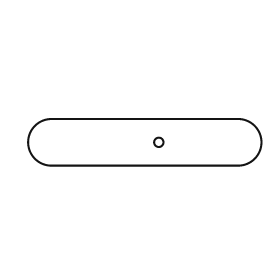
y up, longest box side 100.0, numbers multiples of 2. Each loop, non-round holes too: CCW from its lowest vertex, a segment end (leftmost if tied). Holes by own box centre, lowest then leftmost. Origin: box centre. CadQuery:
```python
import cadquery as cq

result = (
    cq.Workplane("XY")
    .moveTo(-40.0, -10.0)
    .lineTo(40.0, -10.0)
    .threePointArc((50.0, 0.0), (40.0, 10.0))
    .lineTo(-40.0, 10.0)
    .threePointArc((-50.0, 0.0), (-40.0, -10.0))
    .close()
    .moveTo(6.0, 0.0)
    .circle(2.0)
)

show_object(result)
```